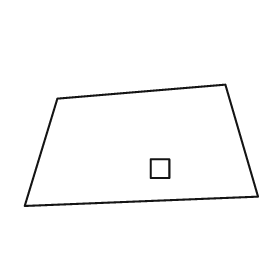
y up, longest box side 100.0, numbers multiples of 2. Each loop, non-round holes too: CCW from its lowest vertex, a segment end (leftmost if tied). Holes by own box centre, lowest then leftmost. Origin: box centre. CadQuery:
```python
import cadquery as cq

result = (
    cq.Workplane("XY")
    .moveTo(-50.0, -26.0)
    .lineTo(50.0, -22.0)
    .lineTo(36.0, 26.0)
    .lineTo(-36.0, 20.0)
    .close()
    .moveTo(4.0, -14.0)
    .lineTo(12.0, -14.0)
    .lineTo(12.0, -6.0)
    .lineTo(4.0, -6.0)
    .close()
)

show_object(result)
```